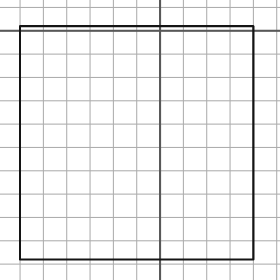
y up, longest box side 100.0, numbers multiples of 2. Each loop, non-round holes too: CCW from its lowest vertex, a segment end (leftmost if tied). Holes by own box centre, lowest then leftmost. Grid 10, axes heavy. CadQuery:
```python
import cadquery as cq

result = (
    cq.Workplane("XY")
    .moveTo(-60.0, -98.0)
    .lineTo(40.0, -98.0)
    .lineTo(40.0, 2.0)
    .lineTo(-60.0, 2.0)
    .close()
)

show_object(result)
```